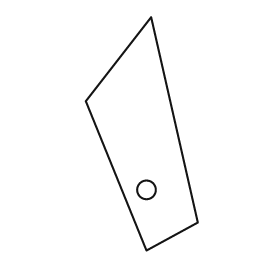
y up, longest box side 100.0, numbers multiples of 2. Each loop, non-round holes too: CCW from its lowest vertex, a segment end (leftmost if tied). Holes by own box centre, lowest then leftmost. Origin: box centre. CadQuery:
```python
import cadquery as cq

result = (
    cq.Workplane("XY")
    .moveTo(2.0, -50.0)
    .lineTo(24.0, -38.0)
    .lineTo(4.0, 50.0)
    .lineTo(-24.0, 14.0)
    .close()
    .moveTo(2.0, -24.0)
    .circle(4.0)
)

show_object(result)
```